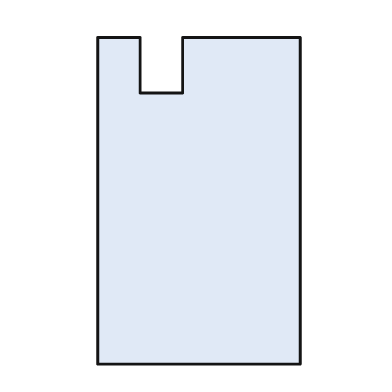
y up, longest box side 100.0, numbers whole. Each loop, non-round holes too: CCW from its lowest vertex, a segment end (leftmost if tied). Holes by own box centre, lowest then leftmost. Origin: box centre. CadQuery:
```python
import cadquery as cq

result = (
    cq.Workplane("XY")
    .moveTo(-31.0, -50.0)
    .lineTo(31.0, -50.0)
    .lineTo(31.0, 50.0)
    .lineTo(-5.0, 50.0)
    .lineTo(-5.0, 33.0)
    .lineTo(-18.0, 33.0)
    .lineTo(-18.0, 50.0)
    .lineTo(-31.0, 50.0)
    .close()
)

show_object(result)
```